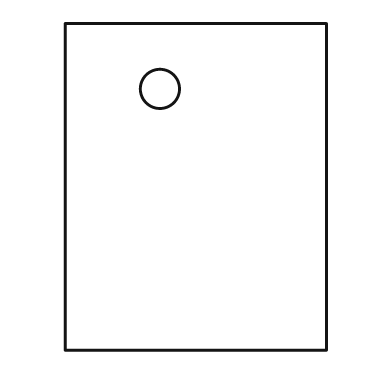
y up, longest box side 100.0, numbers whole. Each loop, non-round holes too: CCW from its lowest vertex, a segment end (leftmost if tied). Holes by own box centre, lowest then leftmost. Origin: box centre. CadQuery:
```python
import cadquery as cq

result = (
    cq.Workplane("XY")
    .moveTo(-40.0, -50.0)
    .lineTo(40.0, -50.0)
    .lineTo(40.0, 50.0)
    .lineTo(-40.0, 50.0)
    .close()
    .moveTo(-11.0, 30.0)
    .circle(6.0)
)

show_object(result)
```